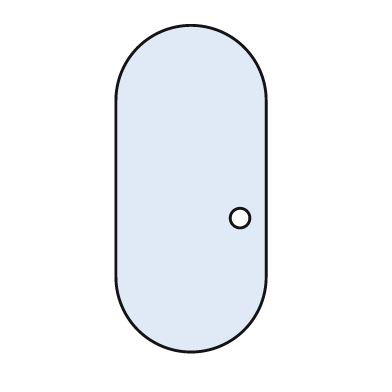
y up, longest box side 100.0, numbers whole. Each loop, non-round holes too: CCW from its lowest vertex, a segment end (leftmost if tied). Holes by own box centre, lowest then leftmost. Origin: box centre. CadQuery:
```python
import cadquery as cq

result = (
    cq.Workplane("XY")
    .moveTo(-23.0, -27.0)
    .threePointArc((0.0, -50.0), (23.0, -27.0))
    .lineTo(23.0, 27.0)
    .threePointArc((0.0, 50.0), (-23.0, 27.0))
    .close()
    .moveTo(15.0, -9.0)
    .circle(3.0)
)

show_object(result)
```